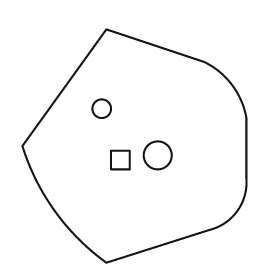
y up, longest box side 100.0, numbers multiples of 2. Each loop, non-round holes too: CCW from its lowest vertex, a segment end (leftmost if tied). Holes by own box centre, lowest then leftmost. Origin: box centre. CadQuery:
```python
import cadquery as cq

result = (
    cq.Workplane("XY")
    .moveTo(-12.0, -50.0)
    .lineTo(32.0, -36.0)
    .threePointArc((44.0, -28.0), (48.0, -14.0))
    .lineTo(48.0, 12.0)
    .threePointArc((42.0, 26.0), (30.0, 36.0))
    .lineTo(-12.0, 50.0)
    .lineTo(-48.0, 0.0)
    .threePointArc((-34.0, -28.0), (-12.0, -50.0))
    .close()
    .moveTo(-10.0, -10.0)
    .lineTo(-2.0, -10.0)
    .lineTo(-2.0, -2.0)
    .lineTo(-10.0, -2.0)
    .close()
    .moveTo(10.0, -4.0)
    .circle(6.0)
    .moveTo(-14.0, 16.0)
    .circle(4.0)
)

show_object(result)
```